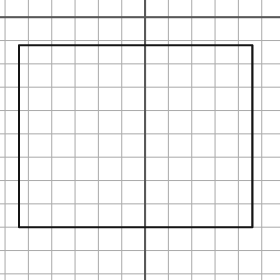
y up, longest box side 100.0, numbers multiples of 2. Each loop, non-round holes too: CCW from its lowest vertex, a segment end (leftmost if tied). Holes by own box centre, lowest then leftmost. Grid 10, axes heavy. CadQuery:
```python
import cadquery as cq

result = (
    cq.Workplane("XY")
    .moveTo(-54.0, -90.0)
    .lineTo(46.0, -90.0)
    .lineTo(46.0, -12.0)
    .lineTo(-54.0, -12.0)
    .close()
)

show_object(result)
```